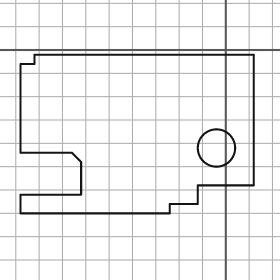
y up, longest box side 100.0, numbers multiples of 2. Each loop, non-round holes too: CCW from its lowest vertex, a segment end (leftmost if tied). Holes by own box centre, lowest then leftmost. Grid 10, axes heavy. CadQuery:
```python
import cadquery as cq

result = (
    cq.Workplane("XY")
    .moveTo(-88.0, -70.0)
    .lineTo(-24.0, -70.0)
    .lineTo(-24.0, -66.0)
    .lineTo(-12.0, -66.0)
    .lineTo(-12.0, -58.0)
    .lineTo(12.0, -58.0)
    .lineTo(12.0, -2.0)
    .lineTo(-82.0, -2.0)
    .lineTo(-82.0, -6.0)
    .lineTo(-88.0, -6.0)
    .lineTo(-88.0, -44.0)
    .lineTo(-66.0, -44.0)
    .lineTo(-62.0, -48.0)
    .lineTo(-62.0, -62.0)
    .lineTo(-88.0, -62.0)
    .close()
    .moveTo(-4.0, -42.0)
    .circle(8.0)
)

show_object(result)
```